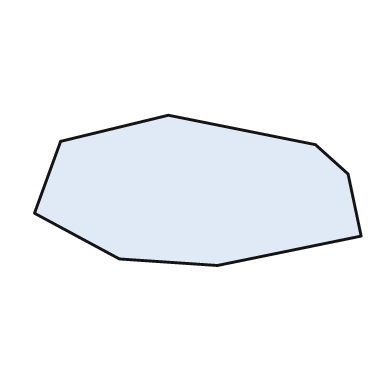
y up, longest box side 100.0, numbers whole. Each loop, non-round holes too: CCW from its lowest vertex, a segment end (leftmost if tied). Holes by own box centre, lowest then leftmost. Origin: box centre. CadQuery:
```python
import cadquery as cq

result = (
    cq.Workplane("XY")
    .moveTo(6.0, -23.0)
    .lineTo(50.0, -14.0)
    .lineTo(46.0, 5.0)
    .lineTo(36.0, 14.0)
    .lineTo(-9.0, 23.0)
    .lineTo(-42.0, 15.0)
    .lineTo(-50.0, -7.0)
    .lineTo(-24.0, -21.0)
    .close()
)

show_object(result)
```